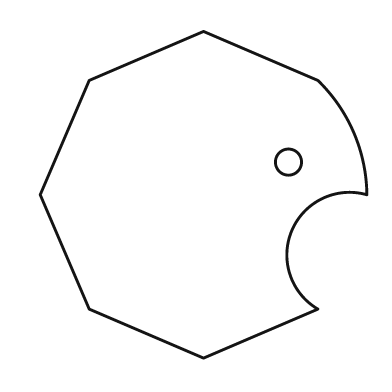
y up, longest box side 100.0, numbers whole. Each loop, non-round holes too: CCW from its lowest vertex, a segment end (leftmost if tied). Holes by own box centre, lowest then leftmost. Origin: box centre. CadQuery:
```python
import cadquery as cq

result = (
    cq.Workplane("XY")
    .moveTo(0.0, -50.0)
    .lineTo(35.0, -35.0)
    .threePointArc((27.0, -11.0), (50.0, 0.0))
    .threePointArc((46.0, 19.0), (35.0, 35.0))
    .lineTo(0.0, 50.0)
    .lineTo(-35.0, 35.0)
    .lineTo(-50.0, 0.0)
    .lineTo(-35.0, -35.0)
    .close()
    .moveTo(26.0, 10.0)
    .circle(4.0)
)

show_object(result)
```